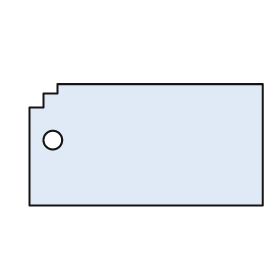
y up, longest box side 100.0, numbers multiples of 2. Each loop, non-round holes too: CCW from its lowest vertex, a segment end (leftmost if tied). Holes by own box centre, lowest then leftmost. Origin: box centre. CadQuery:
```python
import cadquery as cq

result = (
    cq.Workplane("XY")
    .moveTo(-50.0, -26.0)
    .lineTo(50.0, -26.0)
    .lineTo(50.0, 26.0)
    .lineTo(-38.0, 26.0)
    .lineTo(-38.0, 22.0)
    .lineTo(-44.0, 22.0)
    .lineTo(-44.0, 16.0)
    .lineTo(-50.0, 16.0)
    .close()
    .moveTo(-40.0, 2.0)
    .circle(4.0)
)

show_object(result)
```